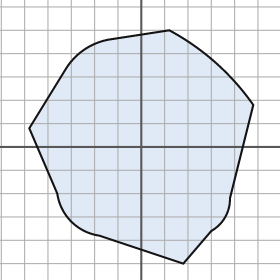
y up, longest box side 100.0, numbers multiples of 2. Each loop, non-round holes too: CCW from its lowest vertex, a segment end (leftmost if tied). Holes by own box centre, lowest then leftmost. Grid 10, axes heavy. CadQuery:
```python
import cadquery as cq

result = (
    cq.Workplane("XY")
    .moveTo(18.0, -50.0)
    .lineTo(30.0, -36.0)
    .threePointArc((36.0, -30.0), (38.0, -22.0))
    .lineTo(48.0, 18.0)
    .threePointArc((32.0, 36.0), (12.0, 50.0))
    .lineTo(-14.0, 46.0)
    .threePointArc((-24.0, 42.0), (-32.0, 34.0))
    .lineTo(-48.0, 8.0)
    .lineTo(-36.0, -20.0)
    .threePointArc((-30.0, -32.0), (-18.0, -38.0))
    .close()
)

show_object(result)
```